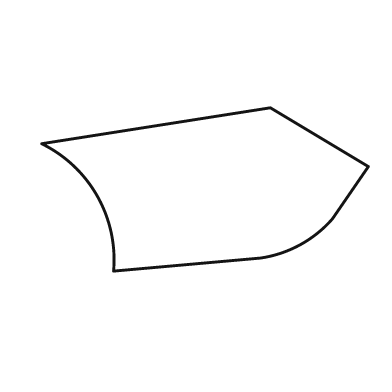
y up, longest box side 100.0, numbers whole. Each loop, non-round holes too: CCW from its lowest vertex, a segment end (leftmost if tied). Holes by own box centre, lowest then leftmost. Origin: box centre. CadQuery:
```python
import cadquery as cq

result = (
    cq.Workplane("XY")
    .moveTo(-28.0, -25.0)
    .lineTo(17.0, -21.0)
    .threePointArc((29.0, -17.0), (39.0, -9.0))
    .lineTo(50.0, 7.0)
    .lineTo(20.0, 25.0)
    .lineTo(-50.0, 14.0)
    .threePointArc((-33.0, -2.0), (-28.0, -25.0))
    .close()
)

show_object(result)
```